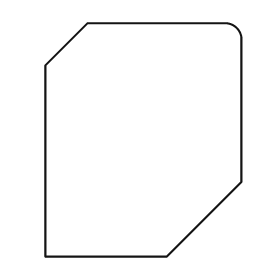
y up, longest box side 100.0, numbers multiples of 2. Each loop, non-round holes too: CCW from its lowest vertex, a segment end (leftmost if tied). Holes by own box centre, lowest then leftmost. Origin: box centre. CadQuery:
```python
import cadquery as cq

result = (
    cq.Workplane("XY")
    .moveTo(-42.0, -50.0)
    .lineTo(10.0, -50.0)
    .lineTo(42.0, -18.0)
    .lineTo(42.0, 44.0)
    .threePointArc((40.0, 48.0), (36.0, 50.0))
    .lineTo(-24.0, 50.0)
    .lineTo(-42.0, 32.0)
    .close()
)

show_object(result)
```